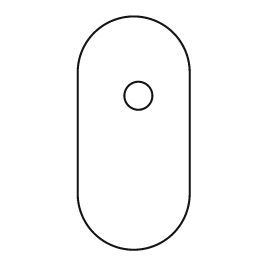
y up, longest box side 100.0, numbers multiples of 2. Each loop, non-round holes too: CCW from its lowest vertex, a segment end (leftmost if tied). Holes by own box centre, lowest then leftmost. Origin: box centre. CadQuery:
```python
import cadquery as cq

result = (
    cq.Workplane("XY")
    .moveTo(-24.0, -26.0)
    .threePointArc((0.0, -50.0), (24.0, -26.0))
    .lineTo(24.0, 26.0)
    .threePointArc((0.0, 50.0), (-24.0, 26.0))
    .close()
    .moveTo(2.0, 16.0)
    .circle(6.0)
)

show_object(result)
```